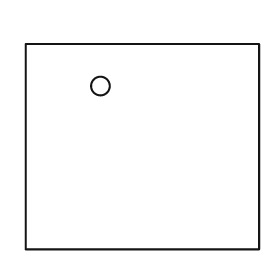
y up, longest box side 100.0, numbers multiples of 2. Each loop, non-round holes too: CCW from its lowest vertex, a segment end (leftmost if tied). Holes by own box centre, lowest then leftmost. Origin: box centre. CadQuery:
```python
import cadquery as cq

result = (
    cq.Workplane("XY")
    .moveTo(-50.0, -44.0)
    .lineTo(50.0, -44.0)
    .lineTo(50.0, 44.0)
    .lineTo(-50.0, 44.0)
    .close()
    .moveTo(-18.0, 26.0)
    .circle(4.0)
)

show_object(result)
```